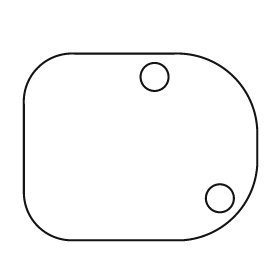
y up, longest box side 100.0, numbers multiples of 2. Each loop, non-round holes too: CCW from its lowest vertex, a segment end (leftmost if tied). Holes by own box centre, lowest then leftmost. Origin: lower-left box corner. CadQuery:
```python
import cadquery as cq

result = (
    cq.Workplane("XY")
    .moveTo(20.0, 0.0)
    .lineTo(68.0, 0.0)
    .threePointArc((90.0, 10.0), (100.0, 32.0))
    .lineTo(100.0, 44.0)
    .threePointArc((90.0, 70.0), (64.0, 80.0))
    .lineTo(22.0, 80.0)
    .threePointArc((6.0, 74.0), (0.0, 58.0))
    .lineTo(0.0, 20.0)
    .threePointArc((6.0, 6.0), (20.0, 0.0))
    .close()
    .moveTo(84.0, 18.0)
    .circle(6.0)
    .moveTo(56.0, 70.0)
    .circle(6.0)
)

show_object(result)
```